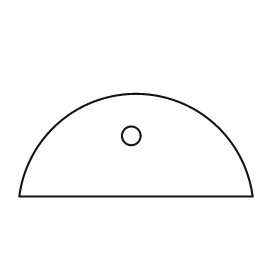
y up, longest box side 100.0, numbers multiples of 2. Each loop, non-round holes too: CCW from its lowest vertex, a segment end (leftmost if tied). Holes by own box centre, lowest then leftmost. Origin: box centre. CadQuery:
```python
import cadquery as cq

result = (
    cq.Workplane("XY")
    .moveTo(-50.0, -22.0)
    .lineTo(50.0, -22.0)
    .threePointArc((0.0, 22.0), (-50.0, -22.0))
    .close()
    .moveTo(-2.0, 4.0)
    .circle(4.0)
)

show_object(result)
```